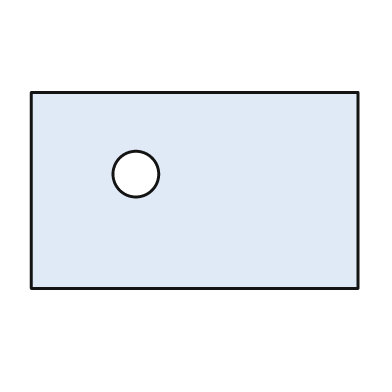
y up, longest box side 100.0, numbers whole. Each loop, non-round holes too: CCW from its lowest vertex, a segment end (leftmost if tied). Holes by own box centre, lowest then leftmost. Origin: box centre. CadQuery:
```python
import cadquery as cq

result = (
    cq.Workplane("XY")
    .moveTo(-50.0, -30.0)
    .lineTo(50.0, -30.0)
    .lineTo(50.0, 30.0)
    .lineTo(-50.0, 30.0)
    .close()
    .moveTo(-18.0, 5.0)
    .circle(7.0)
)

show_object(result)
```